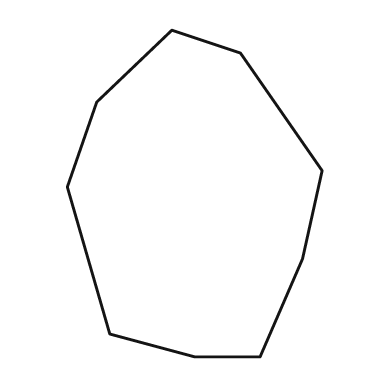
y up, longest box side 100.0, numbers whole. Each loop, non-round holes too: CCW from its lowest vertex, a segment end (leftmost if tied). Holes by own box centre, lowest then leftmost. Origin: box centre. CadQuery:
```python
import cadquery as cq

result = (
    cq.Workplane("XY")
    .moveTo(0.0, -50.0)
    .lineTo(20.0, -50.0)
    .lineTo(33.0, -20.0)
    .lineTo(39.0, 7.0)
    .lineTo(14.0, 43.0)
    .lineTo(-7.0, 50.0)
    .lineTo(-30.0, 28.0)
    .lineTo(-39.0, 2.0)
    .lineTo(-26.0, -43.0)
    .close()
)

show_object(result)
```